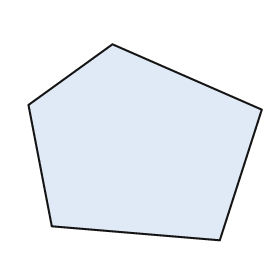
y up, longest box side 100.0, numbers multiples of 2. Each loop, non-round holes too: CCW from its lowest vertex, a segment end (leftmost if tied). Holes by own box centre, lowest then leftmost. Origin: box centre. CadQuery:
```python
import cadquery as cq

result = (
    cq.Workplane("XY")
    .moveTo(32.0, -42.0)
    .lineTo(50.0, 14.0)
    .lineTo(-14.0, 42.0)
    .lineTo(-50.0, 16.0)
    .lineTo(-40.0, -36.0)
    .close()
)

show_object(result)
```